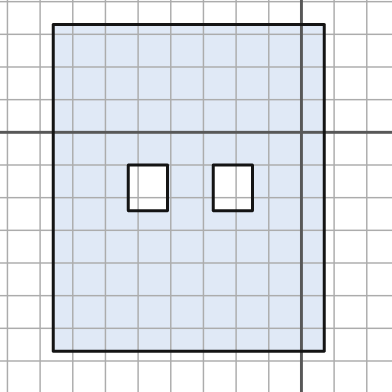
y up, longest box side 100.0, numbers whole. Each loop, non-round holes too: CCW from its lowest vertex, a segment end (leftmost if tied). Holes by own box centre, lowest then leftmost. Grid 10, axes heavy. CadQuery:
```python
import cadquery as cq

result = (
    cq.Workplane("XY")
    .moveTo(-76.0, -67.0)
    .lineTo(7.0, -67.0)
    .lineTo(7.0, 33.0)
    .lineTo(-76.0, 33.0)
    .close()
    .moveTo(-53.0, -24.0)
    .lineTo(-41.0, -24.0)
    .lineTo(-41.0, -10.0)
    .lineTo(-53.0, -10.0)
    .close()
    .moveTo(-27.0, -24.0)
    .lineTo(-15.0, -24.0)
    .lineTo(-15.0, -10.0)
    .lineTo(-27.0, -10.0)
    .close()
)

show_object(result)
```